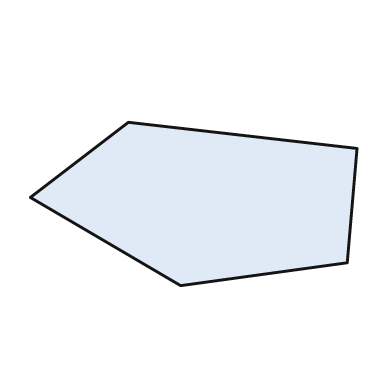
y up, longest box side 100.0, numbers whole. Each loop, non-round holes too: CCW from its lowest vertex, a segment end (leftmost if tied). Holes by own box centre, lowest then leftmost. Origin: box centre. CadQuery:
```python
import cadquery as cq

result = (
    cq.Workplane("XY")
    .moveTo(-4.0, -25.0)
    .lineTo(47.0, -18.0)
    .lineTo(50.0, 17.0)
    .lineTo(-20.0, 25.0)
    .lineTo(-50.0, 2.0)
    .close()
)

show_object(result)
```